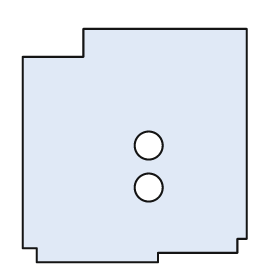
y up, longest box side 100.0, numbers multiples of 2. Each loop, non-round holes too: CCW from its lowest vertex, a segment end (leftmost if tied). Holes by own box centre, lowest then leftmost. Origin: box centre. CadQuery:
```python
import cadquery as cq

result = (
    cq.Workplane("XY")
    .moveTo(-42.0, -50.0)
    .lineTo(10.0, -50.0)
    .lineTo(10.0, -46.0)
    .lineTo(44.0, -46.0)
    .lineTo(44.0, -40.0)
    .lineTo(48.0, -40.0)
    .lineTo(48.0, 50.0)
    .lineTo(-22.0, 50.0)
    .lineTo(-22.0, 38.0)
    .lineTo(-48.0, 38.0)
    .lineTo(-48.0, -44.0)
    .lineTo(-42.0, -44.0)
    .close()
    .moveTo(6.0, -18.0)
    .circle(6.0)
    .moveTo(6.0, 0.0)
    .circle(6.0)
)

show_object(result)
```